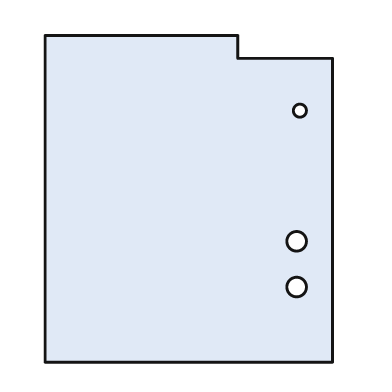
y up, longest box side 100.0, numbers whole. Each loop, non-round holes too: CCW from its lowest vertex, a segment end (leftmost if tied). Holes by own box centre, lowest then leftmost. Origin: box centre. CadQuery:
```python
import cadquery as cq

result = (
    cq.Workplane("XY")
    .moveTo(-44.0, -50.0)
    .lineTo(44.0, -50.0)
    .lineTo(44.0, 43.0)
    .lineTo(15.0, 43.0)
    .lineTo(15.0, 50.0)
    .lineTo(-44.0, 50.0)
    .close()
    .moveTo(33.0, -27.0)
    .circle(3.0)
    .moveTo(33.0, -13.0)
    .circle(3.0)
    .moveTo(34.0, 27.0)
    .circle(2.0)
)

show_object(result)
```